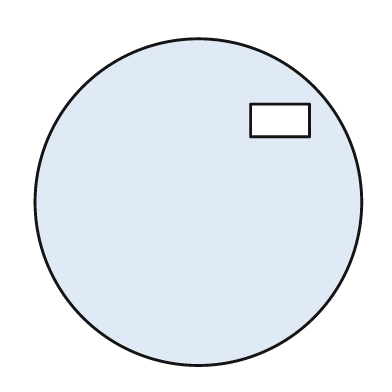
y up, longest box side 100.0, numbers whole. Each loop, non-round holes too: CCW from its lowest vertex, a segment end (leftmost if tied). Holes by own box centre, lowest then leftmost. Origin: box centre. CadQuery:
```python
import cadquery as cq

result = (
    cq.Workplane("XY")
    .moveTo(0.0, 0.0)
    .circle(50.0)
    .moveTo(16.0, 20.0)
    .lineTo(34.0, 20.0)
    .lineTo(34.0, 30.0)
    .lineTo(16.0, 30.0)
    .close()
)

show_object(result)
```